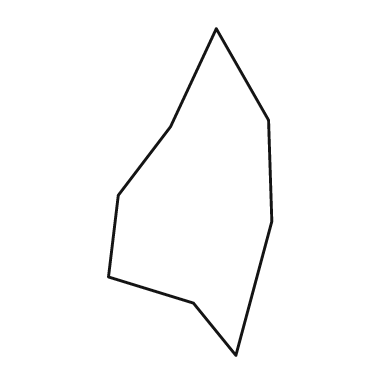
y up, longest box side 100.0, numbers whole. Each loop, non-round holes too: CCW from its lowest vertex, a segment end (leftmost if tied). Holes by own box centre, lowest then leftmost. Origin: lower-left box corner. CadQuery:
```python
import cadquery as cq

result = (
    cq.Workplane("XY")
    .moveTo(39.0, 0.0)
    .lineTo(50.0, 41.0)
    .lineTo(49.0, 72.0)
    .lineTo(33.0, 100.0)
    .lineTo(19.0, 70.0)
    .lineTo(3.0, 49.0)
    .lineTo(0.0, 24.0)
    .lineTo(26.0, 16.0)
    .close()
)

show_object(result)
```